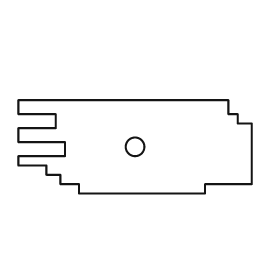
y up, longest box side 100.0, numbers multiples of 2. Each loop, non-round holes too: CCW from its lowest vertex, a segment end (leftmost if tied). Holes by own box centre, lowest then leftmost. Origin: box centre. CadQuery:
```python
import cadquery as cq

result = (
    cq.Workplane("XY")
    .moveTo(-24.0, -20.0)
    .lineTo(30.0, -20.0)
    .lineTo(30.0, -16.0)
    .lineTo(50.0, -16.0)
    .lineTo(50.0, 10.0)
    .lineTo(44.0, 10.0)
    .lineTo(44.0, 14.0)
    .lineTo(40.0, 14.0)
    .lineTo(40.0, 20.0)
    .lineTo(-50.0, 20.0)
    .lineTo(-50.0, 14.0)
    .lineTo(-34.0, 14.0)
    .lineTo(-34.0, 8.0)
    .lineTo(-50.0, 8.0)
    .lineTo(-50.0, 2.0)
    .lineTo(-30.0, 2.0)
    .lineTo(-30.0, -4.0)
    .lineTo(-50.0, -4.0)
    .lineTo(-50.0, -8.0)
    .lineTo(-38.0, -8.0)
    .lineTo(-38.0, -12.0)
    .lineTo(-32.0, -12.0)
    .lineTo(-32.0, -16.0)
    .lineTo(-24.0, -16.0)
    .close()
    .moveTo(0.0, 0.0)
    .circle(4.0)
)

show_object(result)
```